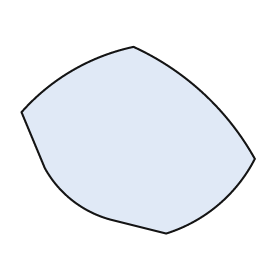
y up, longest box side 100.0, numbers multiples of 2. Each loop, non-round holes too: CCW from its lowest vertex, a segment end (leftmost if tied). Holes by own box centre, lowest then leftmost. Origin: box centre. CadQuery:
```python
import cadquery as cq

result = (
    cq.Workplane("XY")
    .moveTo(12.0, -40.0)
    .threePointArc((34.0, -28.0), (50.0, -8.0))
    .threePointArc((28.0, 20.0), (-2.0, 40.0))
    .threePointArc((-28.0, 30.0), (-50.0, 12.0))
    .lineTo(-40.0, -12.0)
    .threePointArc((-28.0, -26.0), (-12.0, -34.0))
    .close()
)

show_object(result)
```